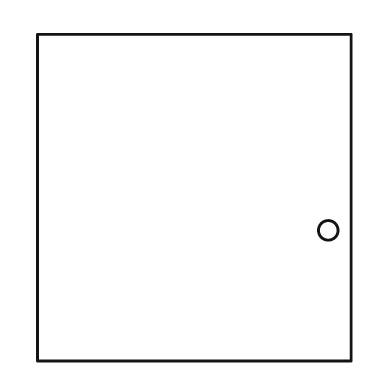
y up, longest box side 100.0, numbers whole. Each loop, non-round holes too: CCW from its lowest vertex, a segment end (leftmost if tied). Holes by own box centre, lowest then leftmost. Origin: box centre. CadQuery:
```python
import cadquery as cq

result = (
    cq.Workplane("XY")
    .moveTo(-48.0, -50.0)
    .lineTo(48.0, -50.0)
    .lineTo(48.0, 50.0)
    .lineTo(-48.0, 50.0)
    .close()
    .moveTo(41.0, -10.0)
    .circle(3.0)
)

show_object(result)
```